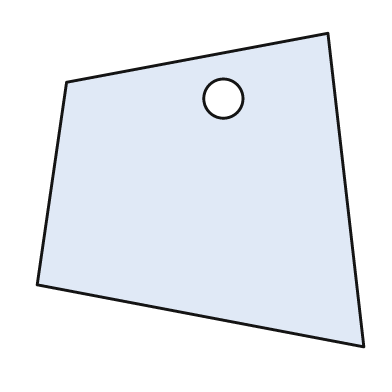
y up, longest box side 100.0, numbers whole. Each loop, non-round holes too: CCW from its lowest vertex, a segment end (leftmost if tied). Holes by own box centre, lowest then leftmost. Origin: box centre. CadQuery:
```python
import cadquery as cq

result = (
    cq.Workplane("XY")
    .moveTo(50.0, -48.0)
    .lineTo(39.0, 48.0)
    .lineTo(-41.0, 33.0)
    .lineTo(-50.0, -29.0)
    .close()
    .moveTo(7.0, 28.0)
    .circle(6.0)
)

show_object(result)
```